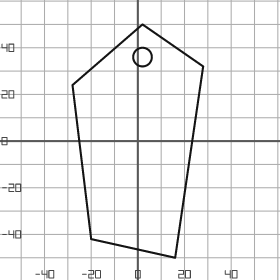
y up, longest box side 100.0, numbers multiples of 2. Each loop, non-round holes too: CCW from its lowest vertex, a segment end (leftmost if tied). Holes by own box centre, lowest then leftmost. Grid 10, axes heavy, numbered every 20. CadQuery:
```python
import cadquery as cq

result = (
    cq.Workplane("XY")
    .moveTo(16.0, -50.0)
    .lineTo(28.0, 32.0)
    .lineTo(2.0, 50.0)
    .lineTo(-28.0, 24.0)
    .lineTo(-20.0, -42.0)
    .close()
    .moveTo(2.0, 36.0)
    .circle(4.0)
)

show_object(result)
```